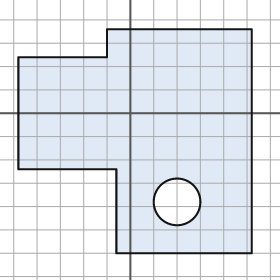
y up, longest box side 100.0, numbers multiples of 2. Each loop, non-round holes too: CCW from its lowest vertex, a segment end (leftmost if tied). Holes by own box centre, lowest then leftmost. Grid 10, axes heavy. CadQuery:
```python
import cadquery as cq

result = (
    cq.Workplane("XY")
    .moveTo(-6.0, -60.0)
    .lineTo(52.0, -60.0)
    .lineTo(52.0, 36.0)
    .lineTo(-10.0, 36.0)
    .lineTo(-10.0, 24.0)
    .lineTo(-48.0, 24.0)
    .lineTo(-48.0, -24.0)
    .lineTo(-6.0, -24.0)
    .close()
    .moveTo(20.0, -38.0)
    .circle(10.0)
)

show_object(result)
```